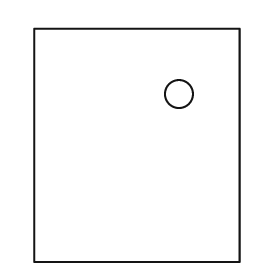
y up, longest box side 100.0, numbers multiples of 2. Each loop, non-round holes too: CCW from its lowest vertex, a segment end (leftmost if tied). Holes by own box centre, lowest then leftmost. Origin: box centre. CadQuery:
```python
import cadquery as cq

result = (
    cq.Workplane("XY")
    .moveTo(-44.0, -50.0)
    .lineTo(44.0, -50.0)
    .lineTo(44.0, 50.0)
    .lineTo(-44.0, 50.0)
    .close()
    .moveTo(18.0, 22.0)
    .circle(6.0)
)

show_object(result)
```